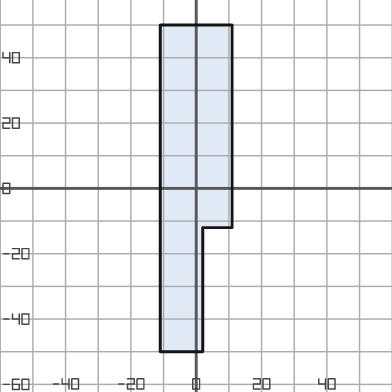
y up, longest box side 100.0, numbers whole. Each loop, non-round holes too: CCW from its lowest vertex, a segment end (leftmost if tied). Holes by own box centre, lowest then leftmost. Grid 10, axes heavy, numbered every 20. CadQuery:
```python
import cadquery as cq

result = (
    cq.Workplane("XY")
    .moveTo(-11.0, -50.0)
    .lineTo(2.0, -50.0)
    .lineTo(2.0, -12.0)
    .lineTo(11.0, -12.0)
    .lineTo(11.0, 50.0)
    .lineTo(-11.0, 50.0)
    .close()
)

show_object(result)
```